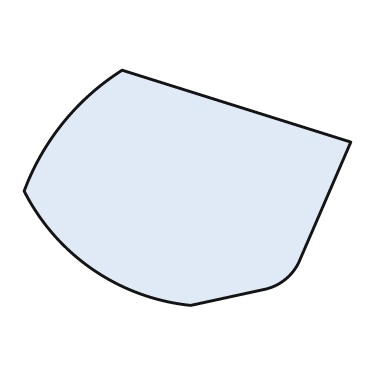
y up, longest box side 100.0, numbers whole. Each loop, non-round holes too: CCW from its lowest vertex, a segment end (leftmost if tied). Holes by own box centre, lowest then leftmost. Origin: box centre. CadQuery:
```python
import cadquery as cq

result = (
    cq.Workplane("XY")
    .moveTo(1.0, -36.0)
    .lineTo(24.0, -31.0)
    .threePointArc((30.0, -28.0), (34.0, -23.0))
    .lineTo(50.0, 14.0)
    .lineTo(-20.0, 36.0)
    .threePointArc((-38.0, 20.0), (-50.0, -1.0))
    .threePointArc((-29.0, -25.0), (1.0, -36.0))
    .close()
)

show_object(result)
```